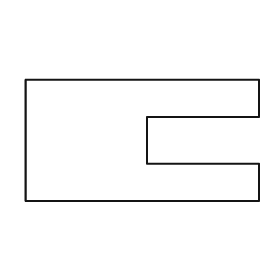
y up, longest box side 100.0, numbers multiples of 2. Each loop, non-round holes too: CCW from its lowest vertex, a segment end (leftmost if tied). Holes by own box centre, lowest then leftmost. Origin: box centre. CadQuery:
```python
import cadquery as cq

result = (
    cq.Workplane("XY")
    .moveTo(-50.0, -26.0)
    .lineTo(50.0, -26.0)
    .lineTo(50.0, -10.0)
    .lineTo(2.0, -10.0)
    .lineTo(2.0, 10.0)
    .lineTo(50.0, 10.0)
    .lineTo(50.0, 26.0)
    .lineTo(-50.0, 26.0)
    .close()
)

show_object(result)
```